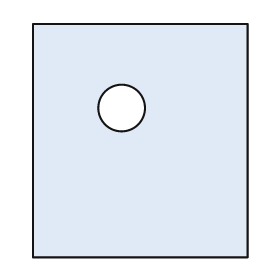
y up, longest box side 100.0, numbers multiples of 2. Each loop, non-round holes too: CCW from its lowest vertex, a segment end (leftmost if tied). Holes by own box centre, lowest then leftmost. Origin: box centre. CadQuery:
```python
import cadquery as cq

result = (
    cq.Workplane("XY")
    .moveTo(-46.0, -50.0)
    .lineTo(46.0, -50.0)
    .lineTo(46.0, 50.0)
    .lineTo(-46.0, 50.0)
    .close()
    .moveTo(-8.0, 14.0)
    .circle(10.0)
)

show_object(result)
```